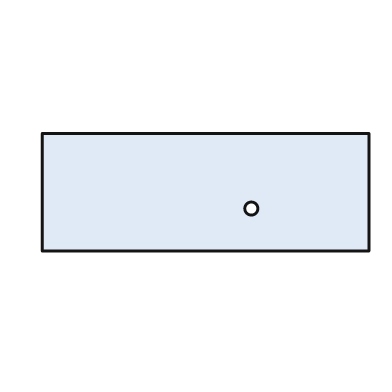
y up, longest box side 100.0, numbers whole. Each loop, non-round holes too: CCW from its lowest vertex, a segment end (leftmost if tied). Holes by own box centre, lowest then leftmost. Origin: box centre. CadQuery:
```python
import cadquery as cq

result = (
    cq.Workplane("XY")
    .moveTo(-50.0, -18.0)
    .lineTo(50.0, -18.0)
    .lineTo(50.0, 18.0)
    .lineTo(-50.0, 18.0)
    .close()
    .moveTo(14.0, -5.0)
    .circle(2.0)
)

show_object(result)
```